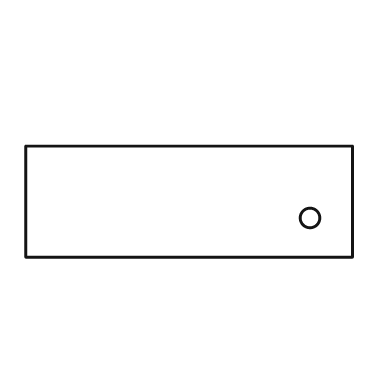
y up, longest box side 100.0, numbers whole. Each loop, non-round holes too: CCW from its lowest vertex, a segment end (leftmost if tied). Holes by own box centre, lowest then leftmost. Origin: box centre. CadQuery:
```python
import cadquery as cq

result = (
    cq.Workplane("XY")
    .moveTo(-50.0, -17.0)
    .lineTo(50.0, -17.0)
    .lineTo(50.0, 17.0)
    .lineTo(-50.0, 17.0)
    .close()
    .moveTo(37.0, -5.0)
    .circle(3.0)
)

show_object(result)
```